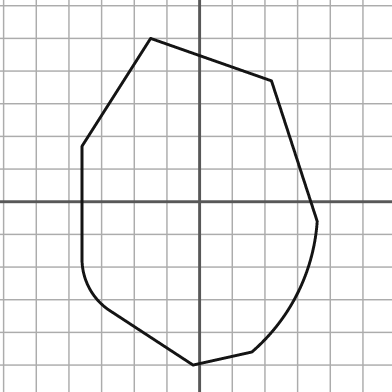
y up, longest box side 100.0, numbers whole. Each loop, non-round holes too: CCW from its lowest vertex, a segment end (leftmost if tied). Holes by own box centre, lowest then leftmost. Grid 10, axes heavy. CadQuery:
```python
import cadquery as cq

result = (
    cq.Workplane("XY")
    .moveTo(-2.0, -50.0)
    .lineTo(16.0, -46.0)
    .threePointArc((30.0, -28.0), (36.0, -6.0))
    .lineTo(22.0, 37.0)
    .lineTo(-15.0, 50.0)
    .lineTo(-36.0, 17.0)
    .lineTo(-36.0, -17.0)
    .threePointArc((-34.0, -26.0), (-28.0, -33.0))
    .close()
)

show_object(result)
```